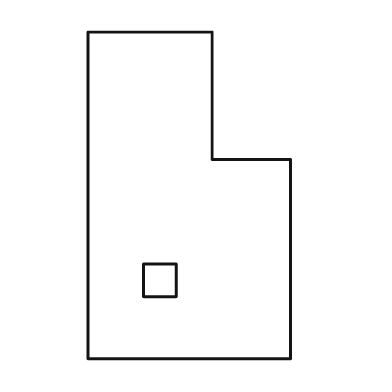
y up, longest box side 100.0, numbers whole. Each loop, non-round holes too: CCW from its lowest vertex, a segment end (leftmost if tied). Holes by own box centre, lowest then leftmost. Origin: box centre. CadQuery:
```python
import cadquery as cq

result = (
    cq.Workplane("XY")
    .moveTo(-31.0, -50.0)
    .lineTo(31.0, -50.0)
    .lineTo(31.0, 11.0)
    .lineTo(7.0, 11.0)
    .lineTo(7.0, 50.0)
    .lineTo(-31.0, 50.0)
    .close()
    .moveTo(-14.0, -31.0)
    .lineTo(-4.0, -31.0)
    .lineTo(-4.0, -21.0)
    .lineTo(-14.0, -21.0)
    .close()
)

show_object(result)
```